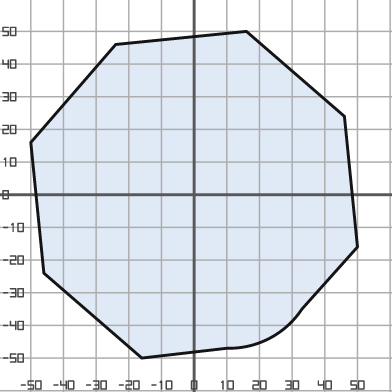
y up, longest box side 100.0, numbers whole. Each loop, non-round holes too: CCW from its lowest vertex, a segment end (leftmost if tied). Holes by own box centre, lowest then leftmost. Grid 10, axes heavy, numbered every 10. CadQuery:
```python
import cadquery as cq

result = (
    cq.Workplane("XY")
    .moveTo(-16.0, -50.0)
    .lineTo(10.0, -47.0)
    .threePointArc((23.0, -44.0), (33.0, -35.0))
    .lineTo(50.0, -16.0)
    .lineTo(46.0, 24.0)
    .lineTo(16.0, 50.0)
    .lineTo(-24.0, 46.0)
    .lineTo(-50.0, 16.0)
    .lineTo(-46.0, -24.0)
    .close()
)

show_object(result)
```